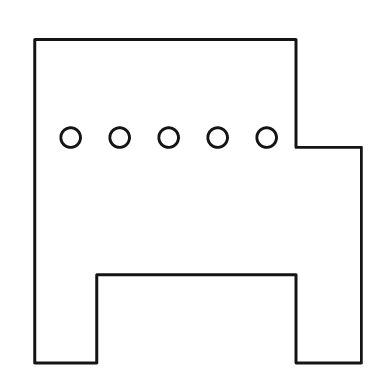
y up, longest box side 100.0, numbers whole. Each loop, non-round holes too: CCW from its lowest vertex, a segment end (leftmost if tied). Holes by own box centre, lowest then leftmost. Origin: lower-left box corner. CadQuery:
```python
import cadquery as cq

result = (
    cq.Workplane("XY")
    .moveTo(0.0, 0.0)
    .lineTo(19.0, 0.0)
    .lineTo(19.0, 27.0)
    .lineTo(80.0, 27.0)
    .lineTo(80.0, 0.0)
    .lineTo(100.0, 0.0)
    .lineTo(100.0, 66.0)
    .lineTo(80.0, 66.0)
    .lineTo(80.0, 99.0)
    .lineTo(0.0, 99.0)
    .close()
    .moveTo(11.0, 69.0)
    .circle(3.0)
    .moveTo(26.0, 69.0)
    .circle(3.0)
    .moveTo(41.0, 69.0)
    .circle(3.0)
    .moveTo(56.0, 69.0)
    .circle(3.0)
    .moveTo(71.0, 69.0)
    .circle(3.0)
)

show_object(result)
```